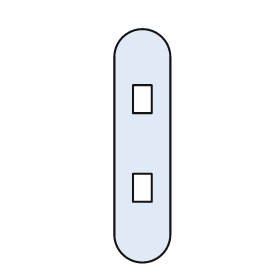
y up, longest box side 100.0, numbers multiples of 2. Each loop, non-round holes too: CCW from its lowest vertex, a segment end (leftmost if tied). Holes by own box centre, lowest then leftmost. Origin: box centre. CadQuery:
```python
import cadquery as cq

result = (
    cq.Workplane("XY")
    .moveTo(-12.0, -38.0)
    .threePointArc((0.0, -50.0), (12.0, -38.0))
    .lineTo(12.0, 38.0)
    .threePointArc((0.0, 50.0), (-12.0, 38.0))
    .close()
    .moveTo(-4.0, -24.0)
    .lineTo(4.0, -24.0)
    .lineTo(4.0, -12.0)
    .lineTo(-4.0, -12.0)
    .close()
    .moveTo(-4.0, 14.0)
    .lineTo(4.0, 14.0)
    .lineTo(4.0, 26.0)
    .lineTo(-4.0, 26.0)
    .close()
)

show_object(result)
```